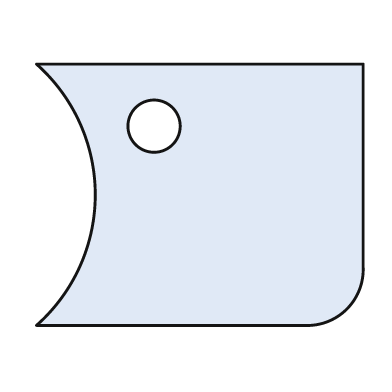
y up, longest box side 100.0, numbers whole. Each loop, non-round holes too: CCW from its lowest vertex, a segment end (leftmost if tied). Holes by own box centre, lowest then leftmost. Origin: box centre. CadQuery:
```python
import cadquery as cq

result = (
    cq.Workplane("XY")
    .moveTo(-50.0, -40.0)
    .lineTo(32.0, -40.0)
    .threePointArc((45.0, -35.0), (50.0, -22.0))
    .lineTo(50.0, 40.0)
    .lineTo(-50.0, 40.0)
    .threePointArc((-32.0, 0.0), (-50.0, -40.0))
    .close()
    .moveTo(-14.0, 21.0)
    .circle(8.0)
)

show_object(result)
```